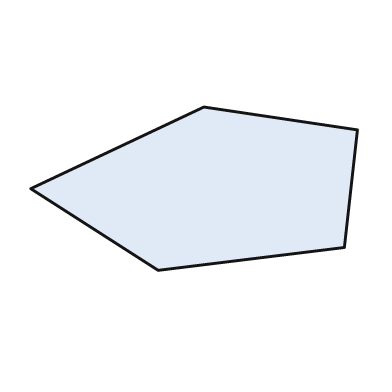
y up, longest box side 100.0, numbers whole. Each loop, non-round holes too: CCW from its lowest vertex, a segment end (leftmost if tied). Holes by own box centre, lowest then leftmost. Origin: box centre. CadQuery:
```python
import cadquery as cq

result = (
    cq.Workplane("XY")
    .moveTo(-11.0, -25.0)
    .lineTo(46.0, -18.0)
    .lineTo(50.0, 18.0)
    .lineTo(3.0, 25.0)
    .lineTo(-50.0, 0.0)
    .close()
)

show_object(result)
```